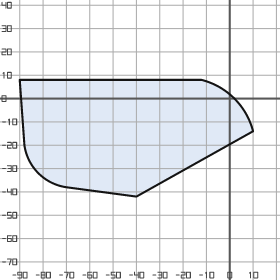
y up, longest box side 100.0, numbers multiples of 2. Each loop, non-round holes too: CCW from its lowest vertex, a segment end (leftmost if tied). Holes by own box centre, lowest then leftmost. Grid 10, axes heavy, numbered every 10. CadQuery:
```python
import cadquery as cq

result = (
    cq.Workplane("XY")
    .moveTo(-40.0, -42.0)
    .lineTo(10.0, -14.0)
    .threePointArc((2.0, 0.0), (-12.0, 8.0))
    .lineTo(-90.0, 8.0)
    .lineTo(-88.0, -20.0)
    .threePointArc((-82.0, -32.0), (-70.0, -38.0))
    .close()
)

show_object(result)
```